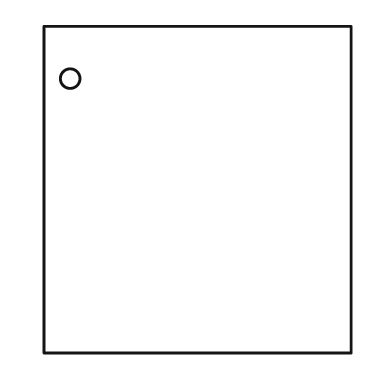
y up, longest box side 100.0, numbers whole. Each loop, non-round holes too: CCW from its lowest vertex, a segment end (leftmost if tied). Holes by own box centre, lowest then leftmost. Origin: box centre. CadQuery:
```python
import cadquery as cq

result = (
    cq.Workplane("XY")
    .moveTo(-47.0, -50.0)
    .lineTo(47.0, -50.0)
    .lineTo(47.0, 50.0)
    .lineTo(-47.0, 50.0)
    .close()
    .moveTo(-39.0, 34.0)
    .circle(3.0)
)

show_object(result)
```